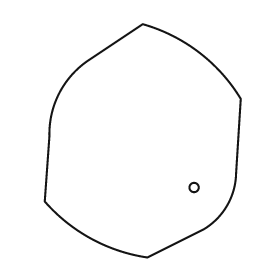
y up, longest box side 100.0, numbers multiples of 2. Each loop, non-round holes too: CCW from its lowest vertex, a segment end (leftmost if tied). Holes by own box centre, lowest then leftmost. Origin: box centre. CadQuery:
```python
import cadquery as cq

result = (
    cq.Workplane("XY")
    .moveTo(2.0, -50.0)
    .lineTo(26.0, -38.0)
    .threePointArc((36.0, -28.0), (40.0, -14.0))
    .lineTo(42.0, 18.0)
    .threePointArc((24.0, 38.0), (0.0, 50.0))
    .lineTo(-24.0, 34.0)
    .threePointArc((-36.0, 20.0), (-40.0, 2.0))
    .lineTo(-42.0, -26.0)
    .threePointArc((-22.0, -42.0), (2.0, -50.0))
    .close()
    .moveTo(22.0, -20.0)
    .circle(2.0)
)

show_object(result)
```